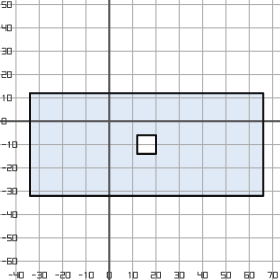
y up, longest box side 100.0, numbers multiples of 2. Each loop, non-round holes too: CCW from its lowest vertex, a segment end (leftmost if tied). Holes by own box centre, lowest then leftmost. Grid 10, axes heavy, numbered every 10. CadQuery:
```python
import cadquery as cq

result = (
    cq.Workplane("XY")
    .moveTo(-34.0, -32.0)
    .lineTo(66.0, -32.0)
    .lineTo(66.0, 12.0)
    .lineTo(-34.0, 12.0)
    .close()
    .moveTo(12.0, -14.0)
    .lineTo(20.0, -14.0)
    .lineTo(20.0, -6.0)
    .lineTo(12.0, -6.0)
    .close()
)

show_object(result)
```